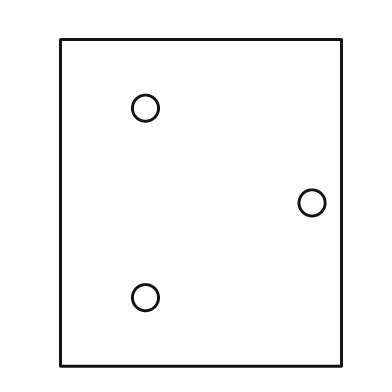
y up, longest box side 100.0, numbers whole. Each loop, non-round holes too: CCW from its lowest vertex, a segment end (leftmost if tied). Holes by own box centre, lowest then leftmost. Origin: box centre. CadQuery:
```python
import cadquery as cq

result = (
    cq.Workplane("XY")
    .moveTo(-43.0, -50.0)
    .lineTo(43.0, -50.0)
    .lineTo(43.0, 50.0)
    .lineTo(-43.0, 50.0)
    .close()
    .moveTo(-17.0, -29.0)
    .circle(4.0)
    .moveTo(34.0, 0.0)
    .circle(4.0)
    .moveTo(-17.0, 29.0)
    .circle(4.0)
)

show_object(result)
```